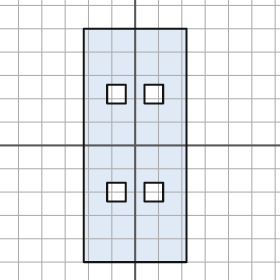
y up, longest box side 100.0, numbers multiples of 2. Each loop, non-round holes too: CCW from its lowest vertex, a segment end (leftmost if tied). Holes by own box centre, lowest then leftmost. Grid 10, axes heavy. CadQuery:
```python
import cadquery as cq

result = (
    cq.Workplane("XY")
    .moveTo(-22.0, -50.0)
    .lineTo(22.0, -50.0)
    .lineTo(22.0, 50.0)
    .lineTo(-22.0, 50.0)
    .close()
    .moveTo(-12.0, -24.0)
    .lineTo(-4.0, -24.0)
    .lineTo(-4.0, -16.0)
    .lineTo(-12.0, -16.0)
    .close()
    .moveTo(4.0, -24.0)
    .lineTo(12.0, -24.0)
    .lineTo(12.0, -16.0)
    .lineTo(4.0, -16.0)
    .close()
    .moveTo(-12.0, 18.0)
    .lineTo(-4.0, 18.0)
    .lineTo(-4.0, 26.0)
    .lineTo(-12.0, 26.0)
    .close()
    .moveTo(4.0, 18.0)
    .lineTo(12.0, 18.0)
    .lineTo(12.0, 26.0)
    .lineTo(4.0, 26.0)
    .close()
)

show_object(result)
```